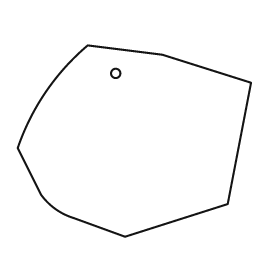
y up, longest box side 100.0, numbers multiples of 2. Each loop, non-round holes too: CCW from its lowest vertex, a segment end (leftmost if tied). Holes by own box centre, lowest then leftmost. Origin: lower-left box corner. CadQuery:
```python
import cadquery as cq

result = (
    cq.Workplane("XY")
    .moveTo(46.0, 0.0)
    .lineTo(90.0, 14.0)
    .lineTo(100.0, 66.0)
    .lineTo(62.0, 78.0)
    .lineTo(30.0, 82.0)
    .threePointArc((12.0, 62.0), (0.0, 38.0))
    .lineTo(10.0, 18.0)
    .threePointArc((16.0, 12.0), (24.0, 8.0))
    .close()
    .moveTo(42.0, 70.0)
    .circle(2.0)
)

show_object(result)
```